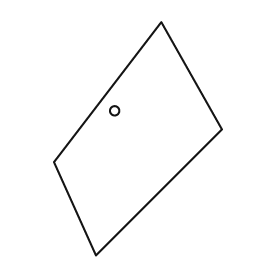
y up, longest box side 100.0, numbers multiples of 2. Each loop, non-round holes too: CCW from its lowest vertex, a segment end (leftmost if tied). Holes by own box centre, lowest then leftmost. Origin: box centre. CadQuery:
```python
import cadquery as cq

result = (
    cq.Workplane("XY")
    .moveTo(-18.0, -50.0)
    .lineTo(36.0, 4.0)
    .lineTo(10.0, 50.0)
    .lineTo(-36.0, -10.0)
    .close()
    .moveTo(-10.0, 12.0)
    .circle(2.0)
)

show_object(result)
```